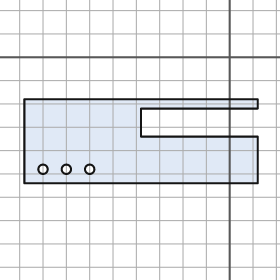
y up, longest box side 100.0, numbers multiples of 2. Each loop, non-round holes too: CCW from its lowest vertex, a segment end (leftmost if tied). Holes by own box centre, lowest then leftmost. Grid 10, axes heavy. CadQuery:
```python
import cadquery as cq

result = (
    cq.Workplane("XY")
    .moveTo(-88.0, -54.0)
    .lineTo(12.0, -54.0)
    .lineTo(12.0, -34.0)
    .lineTo(-38.0, -34.0)
    .lineTo(-38.0, -22.0)
    .lineTo(12.0, -22.0)
    .lineTo(12.0, -18.0)
    .lineTo(-88.0, -18.0)
    .close()
    .moveTo(-80.0, -48.0)
    .circle(2.0)
    .moveTo(-70.0, -48.0)
    .circle(2.0)
    .moveTo(-60.0, -48.0)
    .circle(2.0)
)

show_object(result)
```